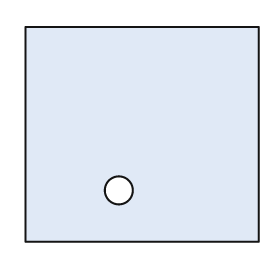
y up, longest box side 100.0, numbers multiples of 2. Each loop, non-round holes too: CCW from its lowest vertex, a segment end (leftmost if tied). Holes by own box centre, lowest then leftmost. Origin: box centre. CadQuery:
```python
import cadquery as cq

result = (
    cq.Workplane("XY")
    .moveTo(-50.0, -46.0)
    .lineTo(50.0, -46.0)
    .lineTo(50.0, 46.0)
    .lineTo(-50.0, 46.0)
    .close()
    .moveTo(-10.0, -24.0)
    .circle(6.0)
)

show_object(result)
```